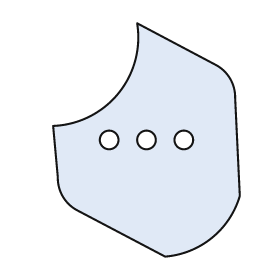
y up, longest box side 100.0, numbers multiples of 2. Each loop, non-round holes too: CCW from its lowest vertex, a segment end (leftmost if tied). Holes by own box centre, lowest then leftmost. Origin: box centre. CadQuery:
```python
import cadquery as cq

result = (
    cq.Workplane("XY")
    .moveTo(8.0, -50.0)
    .threePointArc((28.0, -42.0), (40.0, -24.0))
    .lineTo(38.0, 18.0)
    .threePointArc((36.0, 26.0), (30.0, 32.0))
    .lineTo(-4.0, 50.0)
    .threePointArc((-12.0, 20.0), (-40.0, 6.0))
    .lineTo(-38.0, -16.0)
    .threePointArc((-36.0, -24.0), (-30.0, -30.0))
    .close()
    .moveTo(-16.0, 0.0)
    .circle(4.0)
    .moveTo(0.0, 0.0)
    .circle(4.0)
    .moveTo(16.0, 0.0)
    .circle(4.0)
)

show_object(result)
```